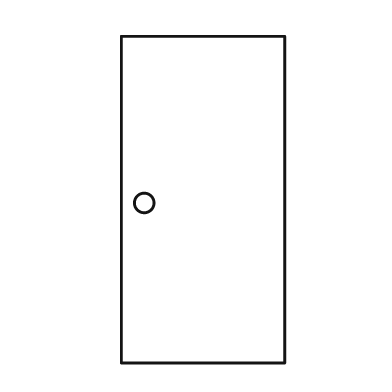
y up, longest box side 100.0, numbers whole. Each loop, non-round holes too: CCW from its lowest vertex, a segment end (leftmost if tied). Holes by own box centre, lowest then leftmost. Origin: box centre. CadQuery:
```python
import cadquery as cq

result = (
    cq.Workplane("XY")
    .moveTo(-25.0, -50.0)
    .lineTo(25.0, -50.0)
    .lineTo(25.0, 50.0)
    .lineTo(-25.0, 50.0)
    .close()
    .moveTo(-18.0, -1.0)
    .circle(3.0)
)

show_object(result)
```